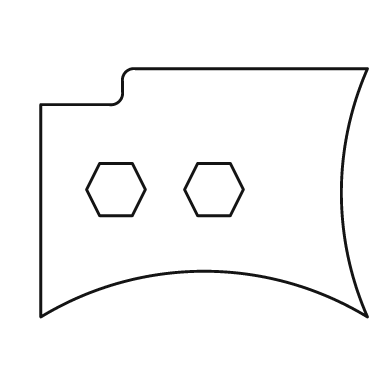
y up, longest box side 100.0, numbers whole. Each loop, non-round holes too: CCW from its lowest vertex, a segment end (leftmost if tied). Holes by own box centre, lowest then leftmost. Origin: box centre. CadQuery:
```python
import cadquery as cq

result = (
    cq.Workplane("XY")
    .moveTo(-50.0, -38.0)
    .threePointArc((0.0, -24.0), (50.0, -38.0))
    .threePointArc((42.0, 0.0), (50.0, 38.0))
    .lineTo(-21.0, 38.0)
    .threePointArc((-24.0, 37.0), (-25.0, 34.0))
    .lineTo(-25.0, 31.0)
    .threePointArc((-26.0, 28.0), (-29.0, 27.0))
    .lineTo(-50.0, 27.0)
    .close()
    .moveTo(-32.0, -7.0)
    .lineTo(-22.0, -7.0)
    .lineTo(-18.0, 1.0)
    .lineTo(-22.0, 9.0)
    .lineTo(-32.0, 9.0)
    .lineTo(-36.0, 1.0)
    .close()
    .moveTo(-2.0, -7.0)
    .lineTo(8.0, -7.0)
    .lineTo(12.0, 1.0)
    .lineTo(8.0, 9.0)
    .lineTo(-2.0, 9.0)
    .lineTo(-6.0, 1.0)
    .close()
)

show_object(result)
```